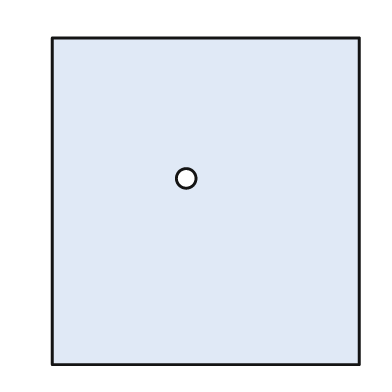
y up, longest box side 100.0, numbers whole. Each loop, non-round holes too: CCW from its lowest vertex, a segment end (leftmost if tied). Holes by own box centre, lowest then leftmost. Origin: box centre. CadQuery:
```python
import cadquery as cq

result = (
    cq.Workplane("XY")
    .moveTo(-47.0, -50.0)
    .lineTo(47.0, -50.0)
    .lineTo(47.0, 50.0)
    .lineTo(-47.0, 50.0)
    .close()
    .moveTo(-6.0, 7.0)
    .circle(3.0)
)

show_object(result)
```